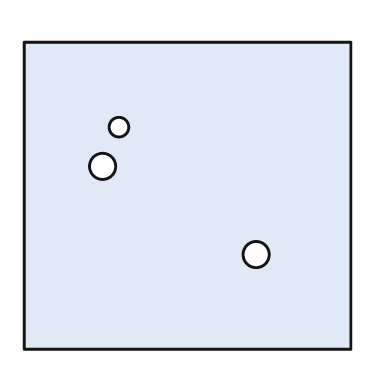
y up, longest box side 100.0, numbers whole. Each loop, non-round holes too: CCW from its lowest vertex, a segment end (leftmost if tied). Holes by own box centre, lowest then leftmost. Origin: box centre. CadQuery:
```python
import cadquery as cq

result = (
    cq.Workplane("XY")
    .moveTo(-50.0, -47.0)
    .lineTo(50.0, -47.0)
    .lineTo(50.0, 47.0)
    .lineTo(-50.0, 47.0)
    .close()
    .moveTo(21.0, -18.0)
    .circle(4.0)
    .moveTo(-26.0, 9.0)
    .circle(4.0)
    .moveTo(-21.0, 21.0)
    .circle(3.0)
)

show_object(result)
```